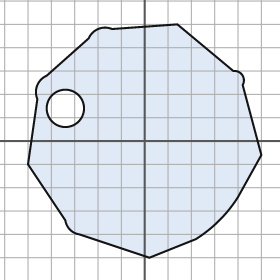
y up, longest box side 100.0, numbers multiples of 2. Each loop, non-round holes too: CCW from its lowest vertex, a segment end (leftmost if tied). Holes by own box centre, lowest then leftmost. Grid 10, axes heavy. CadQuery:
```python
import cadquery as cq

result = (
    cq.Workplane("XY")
    .moveTo(2.0, -50.0)
    .lineTo(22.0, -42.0)
    .threePointArc((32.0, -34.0), (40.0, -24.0))
    .lineTo(50.0, -6.0)
    .lineTo(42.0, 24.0)
    .threePointArc((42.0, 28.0), (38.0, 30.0))
    .lineTo(14.0, 50.0)
    .lineTo(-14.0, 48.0)
    .threePointArc((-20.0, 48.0), (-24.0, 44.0))
    .lineTo(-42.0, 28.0)
    .threePointArc((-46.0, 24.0), (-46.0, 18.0))
    .lineTo(-50.0, -10.0)
    .lineTo(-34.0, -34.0)
    .threePointArc((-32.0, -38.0), (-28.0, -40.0))
    .close()
    .moveTo(-34.0, 14.0)
    .circle(8.0)
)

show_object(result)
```